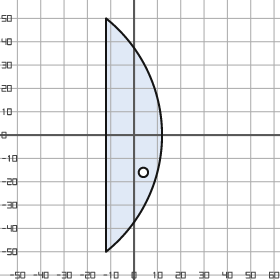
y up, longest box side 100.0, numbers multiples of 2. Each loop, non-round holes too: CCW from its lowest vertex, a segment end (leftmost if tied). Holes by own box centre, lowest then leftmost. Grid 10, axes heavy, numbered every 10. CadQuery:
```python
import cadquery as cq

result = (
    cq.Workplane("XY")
    .moveTo(-12.0, -50.0)
    .threePointArc((12.0, 0.0), (-12.0, 50.0))
    .close()
    .moveTo(4.0, -16.0)
    .circle(2.0)
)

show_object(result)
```